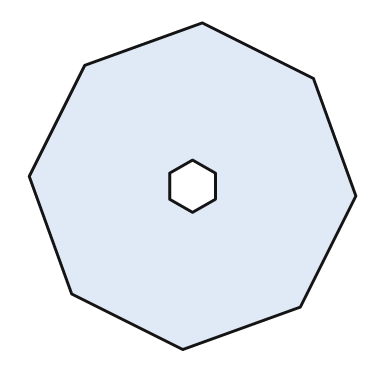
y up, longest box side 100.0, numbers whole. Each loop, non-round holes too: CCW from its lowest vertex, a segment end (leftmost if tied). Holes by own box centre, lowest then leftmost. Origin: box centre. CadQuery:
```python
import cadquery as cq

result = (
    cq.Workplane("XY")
    .moveTo(-3.0, -50.0)
    .lineTo(33.0, -37.0)
    .lineTo(50.0, -3.0)
    .lineTo(37.0, 33.0)
    .lineTo(3.0, 50.0)
    .lineTo(-33.0, 37.0)
    .lineTo(-50.0, 3.0)
    .lineTo(-37.0, -33.0)
    .close()
    .moveTo(0.0, -8.0)
    .lineTo(7.0, -4.0)
    .lineTo(7.0, 4.0)
    .lineTo(0.0, 8.0)
    .lineTo(-7.0, 4.0)
    .lineTo(-7.0, -4.0)
    .close()
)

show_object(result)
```